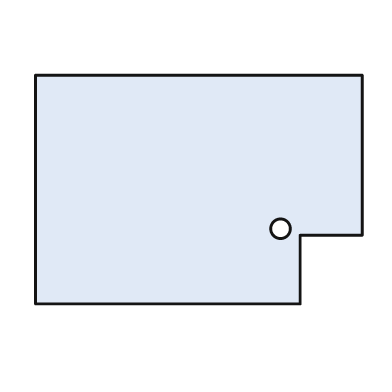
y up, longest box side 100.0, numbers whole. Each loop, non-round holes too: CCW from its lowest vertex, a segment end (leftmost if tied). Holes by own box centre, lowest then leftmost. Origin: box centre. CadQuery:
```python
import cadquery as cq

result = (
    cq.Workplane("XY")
    .moveTo(-50.0, -35.0)
    .lineTo(31.0, -35.0)
    .lineTo(31.0, -14.0)
    .lineTo(50.0, -14.0)
    .lineTo(50.0, 35.0)
    .lineTo(-50.0, 35.0)
    .close()
    .moveTo(25.0, -12.0)
    .circle(3.0)
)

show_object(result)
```